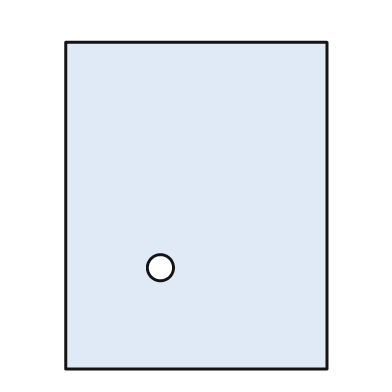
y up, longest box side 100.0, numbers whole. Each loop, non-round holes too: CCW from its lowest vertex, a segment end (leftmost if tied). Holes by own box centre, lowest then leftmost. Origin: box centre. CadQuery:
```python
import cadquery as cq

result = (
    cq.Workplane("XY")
    .moveTo(-40.0, -50.0)
    .lineTo(40.0, -50.0)
    .lineTo(40.0, 50.0)
    .lineTo(-40.0, 50.0)
    .close()
    .moveTo(-11.0, -19.0)
    .circle(4.0)
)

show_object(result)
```